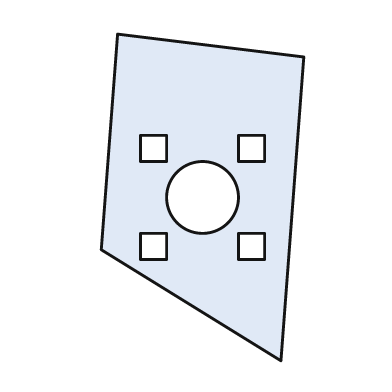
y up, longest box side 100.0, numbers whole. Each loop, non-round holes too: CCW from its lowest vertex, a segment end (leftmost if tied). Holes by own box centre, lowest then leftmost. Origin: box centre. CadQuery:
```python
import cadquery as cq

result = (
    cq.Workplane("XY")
    .moveTo(24.0, -50.0)
    .lineTo(31.0, 43.0)
    .lineTo(-26.0, 50.0)
    .lineTo(-31.0, -16.0)
    .close()
    .moveTo(-19.0, -19.0)
    .lineTo(-11.0, -19.0)
    .lineTo(-11.0, -11.0)
    .lineTo(-19.0, -11.0)
    .close()
    .moveTo(11.0, -19.0)
    .lineTo(19.0, -19.0)
    .lineTo(19.0, -11.0)
    .lineTo(11.0, -11.0)
    .close()
    .moveTo(0.0, 0.0)
    .circle(11.0)
    .moveTo(-19.0, 11.0)
    .lineTo(-11.0, 11.0)
    .lineTo(-11.0, 19.0)
    .lineTo(-19.0, 19.0)
    .close()
    .moveTo(11.0, 11.0)
    .lineTo(19.0, 11.0)
    .lineTo(19.0, 19.0)
    .lineTo(11.0, 19.0)
    .close()
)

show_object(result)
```